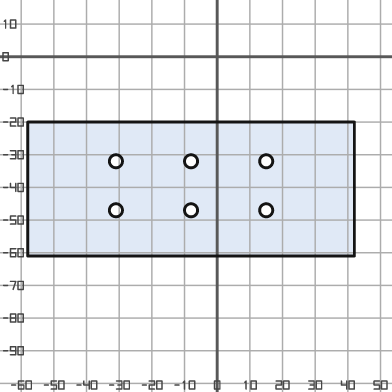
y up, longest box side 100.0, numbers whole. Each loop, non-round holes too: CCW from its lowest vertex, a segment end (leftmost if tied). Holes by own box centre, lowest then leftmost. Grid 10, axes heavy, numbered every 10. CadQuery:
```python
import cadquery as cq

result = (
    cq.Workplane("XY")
    .moveTo(-58.0, -61.0)
    .lineTo(42.0, -61.0)
    .lineTo(42.0, -20.0)
    .lineTo(-58.0, -20.0)
    .close()
    .moveTo(-31.0, -47.0)
    .circle(2.0)
    .moveTo(-8.0, -47.0)
    .circle(2.0)
    .moveTo(15.0, -47.0)
    .circle(2.0)
    .moveTo(-31.0, -32.0)
    .circle(2.0)
    .moveTo(-8.0, -32.0)
    .circle(2.0)
    .moveTo(15.0, -32.0)
    .circle(2.0)
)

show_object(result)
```